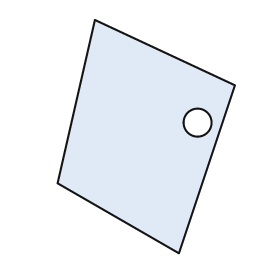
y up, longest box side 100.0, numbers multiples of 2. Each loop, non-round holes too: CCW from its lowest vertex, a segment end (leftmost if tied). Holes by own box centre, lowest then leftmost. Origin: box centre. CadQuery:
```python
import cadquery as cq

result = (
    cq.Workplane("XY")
    .moveTo(14.0, -50.0)
    .lineTo(38.0, 22.0)
    .lineTo(-22.0, 50.0)
    .lineTo(-38.0, -20.0)
    .close()
    .moveTo(22.0, 6.0)
    .circle(6.0)
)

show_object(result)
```